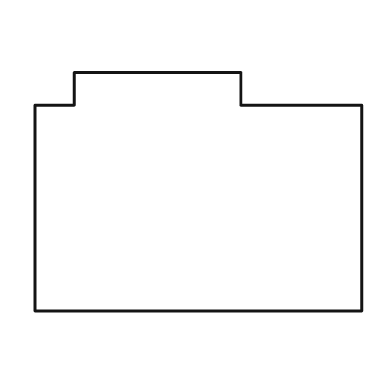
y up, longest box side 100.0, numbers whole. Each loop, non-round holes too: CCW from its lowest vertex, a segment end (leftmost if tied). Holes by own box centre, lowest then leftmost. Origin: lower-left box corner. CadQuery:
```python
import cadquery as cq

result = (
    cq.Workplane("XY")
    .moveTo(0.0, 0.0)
    .lineTo(100.0, 0.0)
    .lineTo(100.0, 63.0)
    .lineTo(63.0, 63.0)
    .lineTo(63.0, 73.0)
    .lineTo(12.0, 73.0)
    .lineTo(12.0, 63.0)
    .lineTo(0.0, 63.0)
    .close()
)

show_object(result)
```